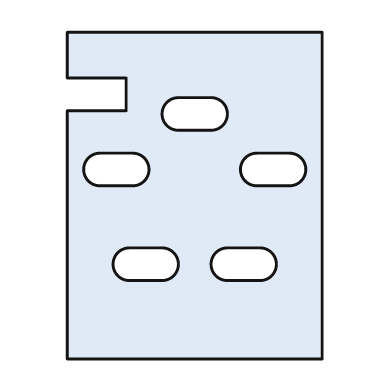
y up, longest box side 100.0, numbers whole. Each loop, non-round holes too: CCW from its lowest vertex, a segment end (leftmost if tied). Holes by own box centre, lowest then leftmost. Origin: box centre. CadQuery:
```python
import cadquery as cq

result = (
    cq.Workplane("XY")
    .moveTo(-39.0, -50.0)
    .lineTo(39.0, -50.0)
    .lineTo(39.0, 50.0)
    .lineTo(-39.0, 50.0)
    .lineTo(-39.0, 36.0)
    .lineTo(-21.0, 36.0)
    .lineTo(-21.0, 26.0)
    .lineTo(-39.0, 26.0)
    .close()
    .moveTo(-20.0, -26.0)
    .lineTo(-10.0, -26.0)
    .threePointArc((-5.0, -21.0), (-10.0, -16.0))
    .lineTo(-20.0, -16.0)
    .threePointArc((-25.0, -21.0), (-20.0, -26.0))
    .close()
    .moveTo(10.0, -26.0)
    .lineTo(20.0, -26.0)
    .threePointArc((25.0, -21.0), (20.0, -16.0))
    .lineTo(10.0, -16.0)
    .threePointArc((5.0, -21.0), (10.0, -26.0))
    .close()
    .moveTo(-29.0, 3.0)
    .lineTo(-19.0, 3.0)
    .threePointArc((-14.0, 8.0), (-19.0, 13.0))
    .lineTo(-29.0, 13.0)
    .threePointArc((-34.0, 8.0), (-29.0, 3.0))
    .close()
    .moveTo(19.0, 3.0)
    .lineTo(29.0, 3.0)
    .threePointArc((34.0, 8.0), (29.0, 13.0))
    .lineTo(19.0, 13.0)
    .threePointArc((14.0, 8.0), (19.0, 3.0))
    .close()
    .moveTo(-5.0, 20.0)
    .lineTo(5.0, 20.0)
    .threePointArc((10.0, 25.0), (5.0, 30.0))
    .lineTo(-5.0, 30.0)
    .threePointArc((-10.0, 25.0), (-5.0, 20.0))
    .close()
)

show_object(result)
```